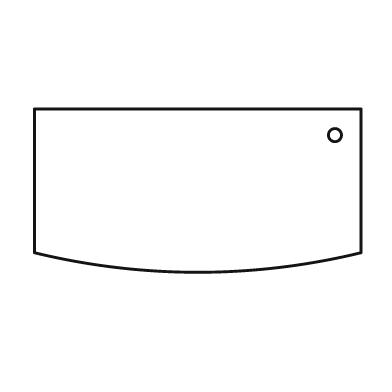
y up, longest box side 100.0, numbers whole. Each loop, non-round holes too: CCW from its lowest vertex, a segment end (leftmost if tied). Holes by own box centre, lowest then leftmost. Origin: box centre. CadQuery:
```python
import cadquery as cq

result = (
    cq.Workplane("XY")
    .moveTo(-50.0, -19.0)
    .threePointArc((0.0, -25.0), (50.0, -19.0))
    .lineTo(50.0, 25.0)
    .lineTo(-50.0, 25.0)
    .close()
    .moveTo(42.0, 17.0)
    .circle(2.0)
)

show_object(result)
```